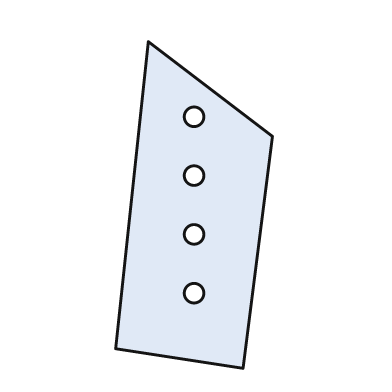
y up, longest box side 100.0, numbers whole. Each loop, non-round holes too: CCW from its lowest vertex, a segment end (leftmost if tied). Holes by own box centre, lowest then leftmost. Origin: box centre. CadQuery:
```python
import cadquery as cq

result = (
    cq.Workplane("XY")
    .moveTo(15.0, -50.0)
    .lineTo(24.0, 21.0)
    .lineTo(-14.0, 50.0)
    .lineTo(-24.0, -44.0)
    .close()
    .moveTo(0.0, -27.0)
    .circle(3.0)
    .moveTo(0.0, -9.0)
    .circle(3.0)
    .moveTo(0.0, 9.0)
    .circle(3.0)
    .moveTo(0.0, 27.0)
    .circle(3.0)
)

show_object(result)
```